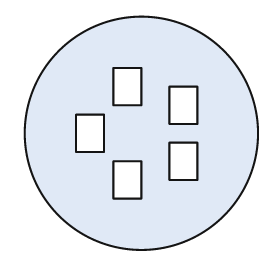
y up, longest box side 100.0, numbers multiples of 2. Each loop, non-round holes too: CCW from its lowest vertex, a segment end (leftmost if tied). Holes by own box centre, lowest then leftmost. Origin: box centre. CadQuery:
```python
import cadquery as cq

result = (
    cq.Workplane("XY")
    .moveTo(0.0, 0.0)
    .circle(50.0)
    .moveTo(-12.0, -28.0)
    .lineTo(0.0, -28.0)
    .lineTo(0.0, -12.0)
    .lineTo(-12.0, -12.0)
    .close()
    .moveTo(12.0, -20.0)
    .lineTo(24.0, -20.0)
    .lineTo(24.0, -4.0)
    .lineTo(12.0, -4.0)
    .close()
    .moveTo(-28.0, -8.0)
    .lineTo(-16.0, -8.0)
    .lineTo(-16.0, 8.0)
    .lineTo(-28.0, 8.0)
    .close()
    .moveTo(12.0, 4.0)
    .lineTo(24.0, 4.0)
    .lineTo(24.0, 20.0)
    .lineTo(12.0, 20.0)
    .close()
    .moveTo(-12.0, 12.0)
    .lineTo(0.0, 12.0)
    .lineTo(0.0, 28.0)
    .lineTo(-12.0, 28.0)
    .close()
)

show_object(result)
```